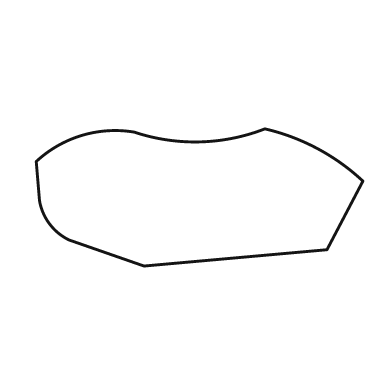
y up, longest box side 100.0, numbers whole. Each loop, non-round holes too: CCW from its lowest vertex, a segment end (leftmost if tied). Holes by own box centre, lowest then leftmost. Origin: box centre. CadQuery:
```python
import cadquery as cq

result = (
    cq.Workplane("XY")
    .moveTo(-17.0, -21.0)
    .lineTo(39.0, -16.0)
    .lineTo(50.0, 5.0)
    .threePointArc((36.0, 15.0), (20.0, 21.0))
    .threePointArc((0.0, 17.0), (-20.0, 20.0))
    .threePointArc((-36.0, 19.0), (-50.0, 11.0))
    .lineTo(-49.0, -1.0)
    .threePointArc((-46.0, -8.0), (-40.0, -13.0))
    .close()
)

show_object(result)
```